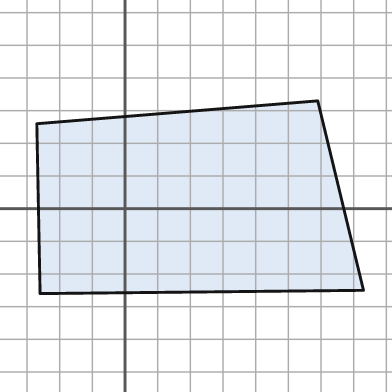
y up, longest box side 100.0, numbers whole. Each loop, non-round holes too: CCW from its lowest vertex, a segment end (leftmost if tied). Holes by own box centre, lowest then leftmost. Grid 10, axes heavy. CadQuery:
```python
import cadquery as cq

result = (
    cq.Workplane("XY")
    .moveTo(-26.0, -26.0)
    .lineTo(73.0, -25.0)
    .lineTo(59.0, 33.0)
    .lineTo(-27.0, 26.0)
    .close()
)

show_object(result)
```